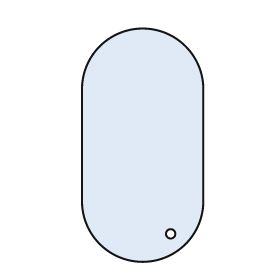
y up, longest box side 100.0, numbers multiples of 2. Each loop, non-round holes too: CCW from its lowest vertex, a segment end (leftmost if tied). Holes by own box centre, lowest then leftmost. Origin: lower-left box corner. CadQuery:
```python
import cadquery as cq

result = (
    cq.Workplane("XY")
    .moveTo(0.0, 26.0)
    .threePointArc((26.0, 0.0), (52.0, 26.0))
    .lineTo(52.0, 74.0)
    .threePointArc((26.0, 100.0), (0.0, 74.0))
    .close()
    .moveTo(38.0, 12.0)
    .circle(2.0)
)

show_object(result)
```